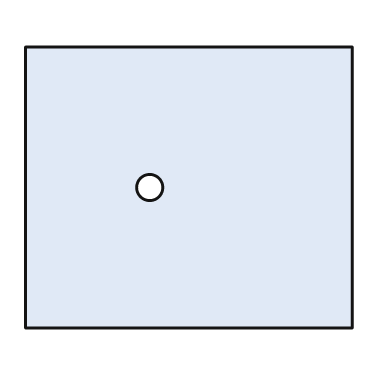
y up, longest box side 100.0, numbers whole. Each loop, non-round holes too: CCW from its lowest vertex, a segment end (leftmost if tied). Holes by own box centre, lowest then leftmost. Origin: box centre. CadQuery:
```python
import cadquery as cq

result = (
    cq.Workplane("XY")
    .moveTo(-50.0, -43.0)
    .lineTo(50.0, -43.0)
    .lineTo(50.0, 43.0)
    .lineTo(-50.0, 43.0)
    .close()
    .moveTo(-12.0, 0.0)
    .circle(4.0)
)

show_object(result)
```